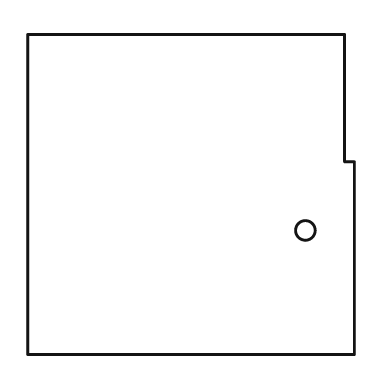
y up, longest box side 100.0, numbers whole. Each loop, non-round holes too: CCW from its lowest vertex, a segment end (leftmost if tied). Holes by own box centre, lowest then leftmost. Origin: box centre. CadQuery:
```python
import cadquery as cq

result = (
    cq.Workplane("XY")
    .moveTo(-50.0, -49.0)
    .lineTo(50.0, -49.0)
    .lineTo(50.0, 10.0)
    .lineTo(47.0, 10.0)
    .lineTo(47.0, 49.0)
    .lineTo(-50.0, 49.0)
    .close()
    .moveTo(35.0, -11.0)
    .circle(3.0)
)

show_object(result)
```